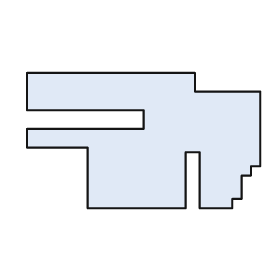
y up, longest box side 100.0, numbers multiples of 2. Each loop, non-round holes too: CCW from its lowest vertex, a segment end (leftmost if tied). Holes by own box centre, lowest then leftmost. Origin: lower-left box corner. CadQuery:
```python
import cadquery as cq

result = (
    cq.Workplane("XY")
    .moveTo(26.0, 0.0)
    .lineTo(68.0, 0.0)
    .lineTo(68.0, 24.0)
    .lineTo(74.0, 24.0)
    .lineTo(74.0, 0.0)
    .lineTo(88.0, 0.0)
    .lineTo(88.0, 4.0)
    .lineTo(92.0, 4.0)
    .lineTo(92.0, 14.0)
    .lineTo(96.0, 14.0)
    .lineTo(96.0, 18.0)
    .lineTo(100.0, 18.0)
    .lineTo(100.0, 50.0)
    .lineTo(72.0, 50.0)
    .lineTo(72.0, 58.0)
    .lineTo(0.0, 58.0)
    .lineTo(0.0, 42.0)
    .lineTo(50.0, 42.0)
    .lineTo(50.0, 34.0)
    .lineTo(0.0, 34.0)
    .lineTo(0.0, 26.0)
    .lineTo(26.0, 26.0)
    .close()
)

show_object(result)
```